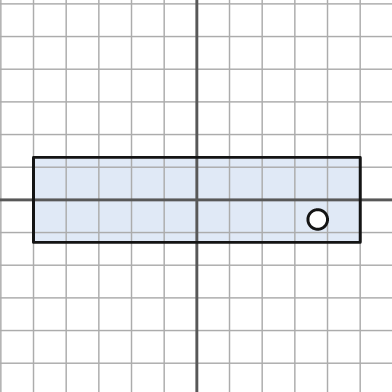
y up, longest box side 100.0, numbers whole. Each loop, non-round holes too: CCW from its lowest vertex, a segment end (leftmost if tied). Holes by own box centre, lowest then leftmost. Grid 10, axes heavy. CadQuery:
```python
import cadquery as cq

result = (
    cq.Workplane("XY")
    .moveTo(-50.0, -13.0)
    .lineTo(50.0, -13.0)
    .lineTo(50.0, 13.0)
    .lineTo(-50.0, 13.0)
    .close()
    .moveTo(37.0, -6.0)
    .circle(3.0)
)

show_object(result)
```